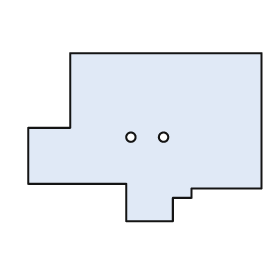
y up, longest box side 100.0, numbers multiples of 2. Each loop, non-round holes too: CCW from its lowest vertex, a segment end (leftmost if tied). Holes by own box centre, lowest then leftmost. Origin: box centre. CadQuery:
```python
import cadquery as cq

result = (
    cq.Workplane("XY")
    .moveTo(-8.0, -36.0)
    .lineTo(12.0, -36.0)
    .lineTo(12.0, -26.0)
    .lineTo(20.0, -26.0)
    .lineTo(20.0, -22.0)
    .lineTo(50.0, -22.0)
    .lineTo(50.0, 36.0)
    .lineTo(-32.0, 36.0)
    .lineTo(-32.0, 4.0)
    .lineTo(-50.0, 4.0)
    .lineTo(-50.0, -20.0)
    .lineTo(-8.0, -20.0)
    .close()
    .moveTo(-6.0, 0.0)
    .circle(2.0)
    .moveTo(8.0, 0.0)
    .circle(2.0)
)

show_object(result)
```